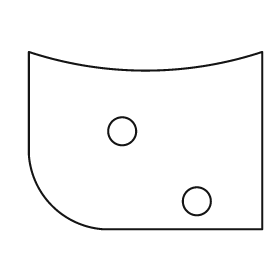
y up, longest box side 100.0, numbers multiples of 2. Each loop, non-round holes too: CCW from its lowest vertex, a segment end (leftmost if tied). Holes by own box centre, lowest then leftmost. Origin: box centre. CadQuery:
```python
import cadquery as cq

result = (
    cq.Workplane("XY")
    .moveTo(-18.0, -38.0)
    .lineTo(50.0, -38.0)
    .lineTo(50.0, 38.0)
    .threePointArc((0.0, 30.0), (-50.0, 38.0))
    .lineTo(-50.0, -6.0)
    .threePointArc((-40.0, -28.0), (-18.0, -38.0))
    .close()
    .moveTo(22.0, -26.0)
    .circle(6.0)
    .moveTo(-10.0, 4.0)
    .circle(6.0)
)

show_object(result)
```